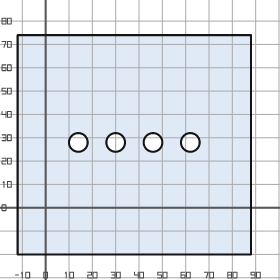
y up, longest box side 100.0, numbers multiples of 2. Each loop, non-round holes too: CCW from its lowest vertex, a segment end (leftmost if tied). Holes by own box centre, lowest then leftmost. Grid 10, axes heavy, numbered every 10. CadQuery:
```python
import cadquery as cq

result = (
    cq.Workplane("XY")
    .moveTo(-12.0, -20.0)
    .lineTo(88.0, -20.0)
    .lineTo(88.0, 74.0)
    .lineTo(-12.0, 74.0)
    .close()
    .moveTo(14.0, 28.0)
    .circle(4.0)
    .moveTo(30.0, 28.0)
    .circle(4.0)
    .moveTo(46.0, 28.0)
    .circle(4.0)
    .moveTo(62.0, 28.0)
    .circle(4.0)
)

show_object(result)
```